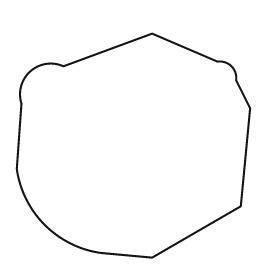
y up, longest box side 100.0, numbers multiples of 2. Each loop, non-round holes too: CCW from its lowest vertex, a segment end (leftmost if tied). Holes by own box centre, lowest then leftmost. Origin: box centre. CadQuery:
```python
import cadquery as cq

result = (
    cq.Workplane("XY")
    .moveTo(8.0, -48.0)
    .lineTo(46.0, -26.0)
    .lineTo(50.0, 16.0)
    .lineTo(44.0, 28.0)
    .threePointArc((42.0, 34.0), (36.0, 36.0))
    .lineTo(8.0, 48.0)
    .lineTo(-30.0, 34.0)
    .threePointArc((-44.0, 32.0), (-48.0, 18.0))
    .lineTo(-50.0, -10.0)
    .threePointArc((-38.0, -34.0), (-14.0, -46.0))
    .close()
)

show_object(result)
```